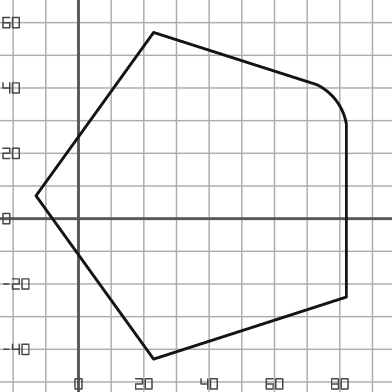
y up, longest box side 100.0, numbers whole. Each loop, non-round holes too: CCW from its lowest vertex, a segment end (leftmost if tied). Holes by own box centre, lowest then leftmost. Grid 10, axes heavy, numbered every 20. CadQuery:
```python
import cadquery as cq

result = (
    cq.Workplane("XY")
    .moveTo(23.0, -43.0)
    .lineTo(82.0, -24.0)
    .lineTo(82.0, 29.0)
    .threePointArc((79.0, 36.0), (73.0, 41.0))
    .lineTo(23.0, 57.0)
    .lineTo(-13.0, 7.0)
    .close()
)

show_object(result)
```